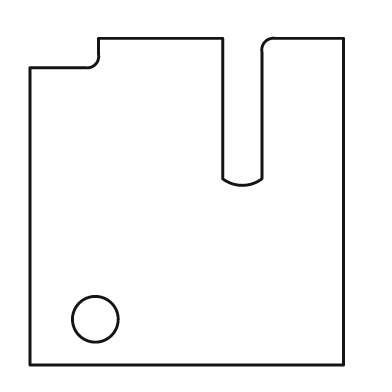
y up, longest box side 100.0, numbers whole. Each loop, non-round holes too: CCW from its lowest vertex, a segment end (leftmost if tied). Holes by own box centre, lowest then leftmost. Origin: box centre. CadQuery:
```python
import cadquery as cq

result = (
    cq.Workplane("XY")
    .moveTo(-48.0, -50.0)
    .lineTo(48.0, -50.0)
    .lineTo(48.0, 50.0)
    .lineTo(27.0, 50.0)
    .threePointArc((24.0, 49.0), (23.0, 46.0))
    .lineTo(23.0, 7.0)
    .threePointArc((17.0, 5.0), (11.0, 7.0))
    .lineTo(11.0, 50.0)
    .lineTo(-27.0, 50.0)
    .lineTo(-27.0, 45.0)
    .threePointArc((-28.0, 42.0), (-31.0, 41.0))
    .lineTo(-48.0, 41.0)
    .close()
    .moveTo(-28.0, -36.0)
    .circle(7.0)
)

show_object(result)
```